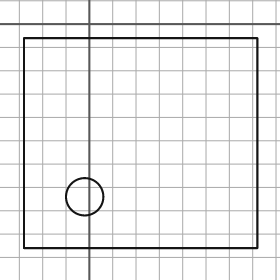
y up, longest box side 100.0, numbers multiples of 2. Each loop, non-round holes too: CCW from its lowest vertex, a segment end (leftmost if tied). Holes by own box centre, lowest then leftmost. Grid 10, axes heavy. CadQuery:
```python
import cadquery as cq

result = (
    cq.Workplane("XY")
    .moveTo(-28.0, -96.0)
    .lineTo(72.0, -96.0)
    .lineTo(72.0, -6.0)
    .lineTo(-28.0, -6.0)
    .close()
    .moveTo(-2.0, -74.0)
    .circle(8.0)
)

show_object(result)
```